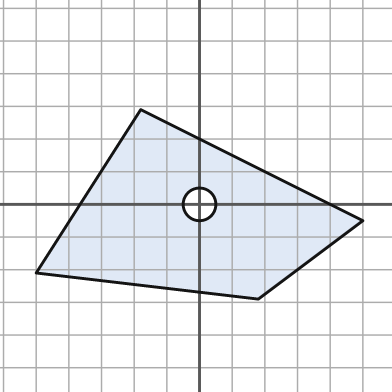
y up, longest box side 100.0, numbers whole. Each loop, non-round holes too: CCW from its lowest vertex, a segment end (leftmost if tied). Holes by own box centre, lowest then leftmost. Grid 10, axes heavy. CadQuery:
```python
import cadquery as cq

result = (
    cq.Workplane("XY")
    .moveTo(18.0, -29.0)
    .lineTo(50.0, -5.0)
    .lineTo(-18.0, 29.0)
    .lineTo(-50.0, -21.0)
    .close()
    .moveTo(0.0, 0.0)
    .circle(5.0)
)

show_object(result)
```